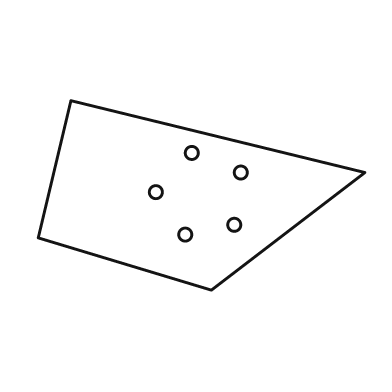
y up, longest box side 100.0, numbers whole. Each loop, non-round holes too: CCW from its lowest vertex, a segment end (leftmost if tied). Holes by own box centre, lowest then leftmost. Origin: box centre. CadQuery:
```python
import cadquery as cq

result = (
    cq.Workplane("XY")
    .moveTo(3.0, -29.0)
    .lineTo(50.0, 7.0)
    .lineTo(-40.0, 29.0)
    .lineTo(-50.0, -13.0)
    .close()
    .moveTo(-5.0, -12.0)
    .circle(2.0)
    .moveTo(10.0, -9.0)
    .circle(2.0)
    .moveTo(-14.0, 1.0)
    .circle(2.0)
    .moveTo(12.0, 7.0)
    .circle(2.0)
    .moveTo(-3.0, 13.0)
    .circle(2.0)
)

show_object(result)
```